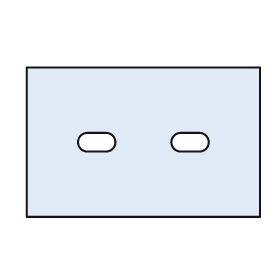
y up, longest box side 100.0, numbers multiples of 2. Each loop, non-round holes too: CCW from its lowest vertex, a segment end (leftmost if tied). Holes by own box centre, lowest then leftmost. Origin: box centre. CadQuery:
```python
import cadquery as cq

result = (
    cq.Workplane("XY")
    .moveTo(-50.0, -32.0)
    .lineTo(50.0, -32.0)
    .lineTo(50.0, 32.0)
    .lineTo(-50.0, 32.0)
    .close()
    .moveTo(-24.0, -4.0)
    .lineTo(-16.0, -4.0)
    .threePointArc((-12.0, 0.0), (-16.0, 4.0))
    .lineTo(-24.0, 4.0)
    .threePointArc((-28.0, 0.0), (-24.0, -4.0))
    .close()
    .moveTo(16.0, -4.0)
    .lineTo(24.0, -4.0)
    .threePointArc((28.0, 0.0), (24.0, 4.0))
    .lineTo(16.0, 4.0)
    .threePointArc((12.0, 0.0), (16.0, -4.0))
    .close()
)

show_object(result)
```